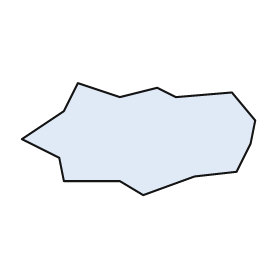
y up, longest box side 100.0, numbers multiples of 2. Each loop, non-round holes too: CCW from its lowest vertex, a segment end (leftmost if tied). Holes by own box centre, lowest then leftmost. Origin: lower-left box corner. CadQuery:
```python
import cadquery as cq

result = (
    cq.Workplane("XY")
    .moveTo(52.0, 0.0)
    .lineTo(74.0, 8.0)
    .lineTo(92.0, 10.0)
    .lineTo(98.0, 22.0)
    .lineTo(100.0, 32.0)
    .lineTo(90.0, 44.0)
    .lineTo(66.0, 42.0)
    .lineTo(58.0, 46.0)
    .lineTo(42.0, 42.0)
    .lineTo(24.0, 48.0)
    .lineTo(18.0, 36.0)
    .lineTo(0.0, 24.0)
    .lineTo(16.0, 16.0)
    .lineTo(18.0, 6.0)
    .lineTo(42.0, 6.0)
    .close()
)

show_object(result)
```